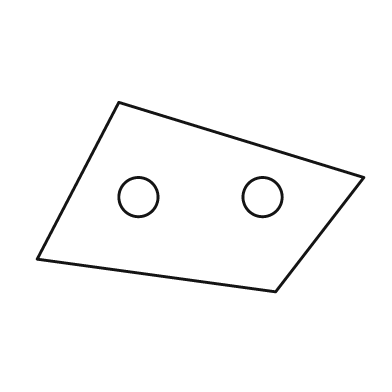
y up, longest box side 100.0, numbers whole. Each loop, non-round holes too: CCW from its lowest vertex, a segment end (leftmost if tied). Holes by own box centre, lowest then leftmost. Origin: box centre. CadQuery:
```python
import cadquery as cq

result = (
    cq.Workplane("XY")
    .moveTo(23.0, -29.0)
    .lineTo(50.0, 6.0)
    .lineTo(-25.0, 29.0)
    .lineTo(-50.0, -19.0)
    .close()
    .moveTo(-19.0, 0.0)
    .circle(6.0)
    .moveTo(19.0, 0.0)
    .circle(6.0)
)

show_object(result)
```